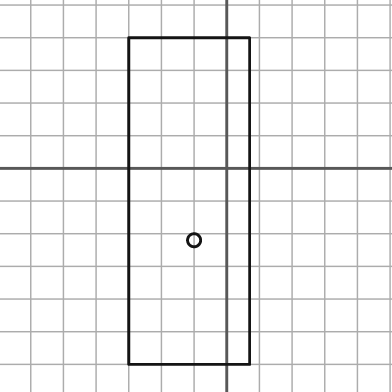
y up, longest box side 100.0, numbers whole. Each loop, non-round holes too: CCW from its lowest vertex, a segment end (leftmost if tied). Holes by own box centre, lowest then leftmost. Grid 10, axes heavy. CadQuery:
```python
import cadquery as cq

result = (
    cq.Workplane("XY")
    .moveTo(-30.0, -60.0)
    .lineTo(7.0, -60.0)
    .lineTo(7.0, 40.0)
    .lineTo(-30.0, 40.0)
    .close()
    .moveTo(-10.0, -22.0)
    .circle(2.0)
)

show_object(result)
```